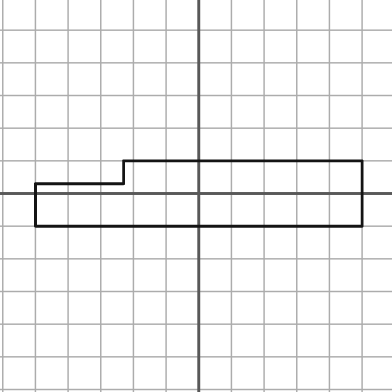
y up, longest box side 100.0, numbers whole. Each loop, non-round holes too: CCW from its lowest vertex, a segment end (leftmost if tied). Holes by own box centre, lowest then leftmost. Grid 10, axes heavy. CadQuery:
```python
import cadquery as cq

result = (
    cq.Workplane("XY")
    .moveTo(-50.0, -10.0)
    .lineTo(50.0, -10.0)
    .lineTo(50.0, 10.0)
    .lineTo(-23.0, 10.0)
    .lineTo(-23.0, 3.0)
    .lineTo(-50.0, 3.0)
    .close()
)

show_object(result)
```